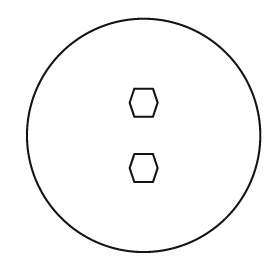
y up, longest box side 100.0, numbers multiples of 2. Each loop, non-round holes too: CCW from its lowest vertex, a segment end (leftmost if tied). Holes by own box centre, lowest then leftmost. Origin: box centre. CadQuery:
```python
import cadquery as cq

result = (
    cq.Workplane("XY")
    .moveTo(0.0, 0.0)
    .circle(50.0)
    .moveTo(-4.0, -20.0)
    .lineTo(4.0, -20.0)
    .lineTo(6.0, -14.0)
    .lineTo(4.0, -8.0)
    .lineTo(-4.0, -8.0)
    .lineTo(-6.0, -14.0)
    .close()
    .moveTo(-4.0, 8.0)
    .lineTo(4.0, 8.0)
    .lineTo(6.0, 14.0)
    .lineTo(4.0, 20.0)
    .lineTo(-4.0, 20.0)
    .lineTo(-6.0, 14.0)
    .close()
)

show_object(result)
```